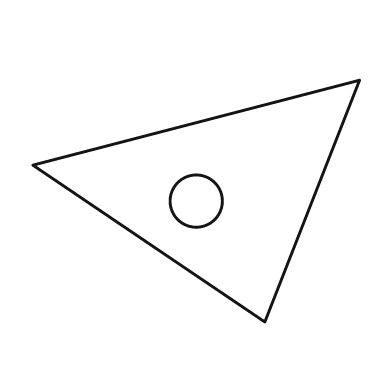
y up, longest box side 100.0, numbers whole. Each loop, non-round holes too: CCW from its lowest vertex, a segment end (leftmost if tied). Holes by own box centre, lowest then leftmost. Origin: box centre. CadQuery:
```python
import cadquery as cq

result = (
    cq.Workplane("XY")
    .moveTo(21.0, -37.0)
    .lineTo(50.0, 37.0)
    .lineTo(-50.0, 11.0)
    .close()
    .moveTo(0.0, 0.0)
    .circle(8.0)
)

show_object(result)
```